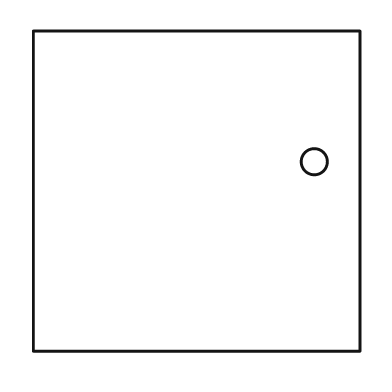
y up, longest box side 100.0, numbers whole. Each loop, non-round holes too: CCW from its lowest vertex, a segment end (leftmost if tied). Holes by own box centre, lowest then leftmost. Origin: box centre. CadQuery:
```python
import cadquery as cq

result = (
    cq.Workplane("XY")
    .moveTo(-50.0, -49.0)
    .lineTo(50.0, -49.0)
    .lineTo(50.0, 49.0)
    .lineTo(-50.0, 49.0)
    .close()
    .moveTo(36.0, 9.0)
    .circle(4.0)
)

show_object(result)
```